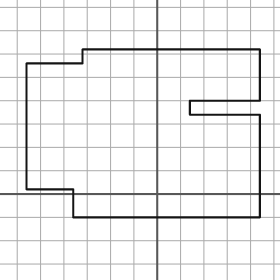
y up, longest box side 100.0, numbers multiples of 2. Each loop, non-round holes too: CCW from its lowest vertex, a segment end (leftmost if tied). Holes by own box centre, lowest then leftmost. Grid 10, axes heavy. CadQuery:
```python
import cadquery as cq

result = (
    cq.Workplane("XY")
    .moveTo(-36.0, -10.0)
    .lineTo(44.0, -10.0)
    .lineTo(44.0, 34.0)
    .lineTo(14.0, 34.0)
    .lineTo(14.0, 40.0)
    .lineTo(44.0, 40.0)
    .lineTo(44.0, 62.0)
    .lineTo(-32.0, 62.0)
    .lineTo(-32.0, 56.0)
    .lineTo(-56.0, 56.0)
    .lineTo(-56.0, 2.0)
    .lineTo(-36.0, 2.0)
    .close()
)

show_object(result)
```